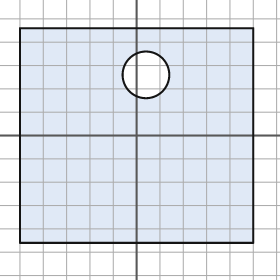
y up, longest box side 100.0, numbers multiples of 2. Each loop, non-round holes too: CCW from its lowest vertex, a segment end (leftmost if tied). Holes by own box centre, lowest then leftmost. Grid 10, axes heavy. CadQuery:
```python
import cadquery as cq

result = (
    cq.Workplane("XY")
    .moveTo(-50.0, -46.0)
    .lineTo(50.0, -46.0)
    .lineTo(50.0, 46.0)
    .lineTo(-50.0, 46.0)
    .close()
    .moveTo(4.0, 26.0)
    .circle(10.0)
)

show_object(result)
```